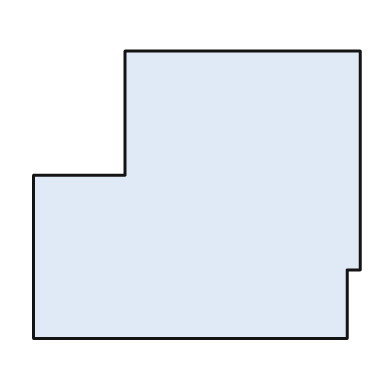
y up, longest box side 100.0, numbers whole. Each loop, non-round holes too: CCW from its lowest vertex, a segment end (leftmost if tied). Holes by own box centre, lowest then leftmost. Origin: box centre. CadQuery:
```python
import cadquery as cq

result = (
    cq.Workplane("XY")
    .moveTo(-50.0, -44.0)
    .lineTo(46.0, -44.0)
    .lineTo(46.0, -23.0)
    .lineTo(50.0, -23.0)
    .lineTo(50.0, 44.0)
    .lineTo(-22.0, 44.0)
    .lineTo(-22.0, 6.0)
    .lineTo(-50.0, 6.0)
    .close()
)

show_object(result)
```